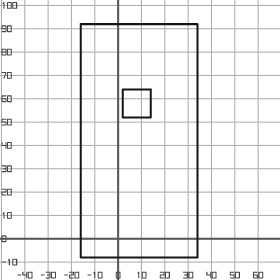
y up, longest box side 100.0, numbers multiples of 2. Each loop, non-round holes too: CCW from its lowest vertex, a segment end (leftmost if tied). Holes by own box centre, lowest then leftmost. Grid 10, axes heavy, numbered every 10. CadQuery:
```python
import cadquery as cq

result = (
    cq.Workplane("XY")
    .moveTo(-16.0, -8.0)
    .lineTo(34.0, -8.0)
    .lineTo(34.0, 92.0)
    .lineTo(-16.0, 92.0)
    .close()
    .moveTo(2.0, 52.0)
    .lineTo(14.0, 52.0)
    .lineTo(14.0, 64.0)
    .lineTo(2.0, 64.0)
    .close()
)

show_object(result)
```